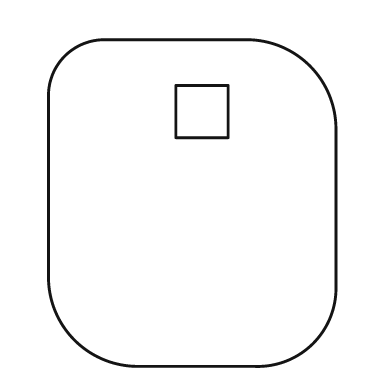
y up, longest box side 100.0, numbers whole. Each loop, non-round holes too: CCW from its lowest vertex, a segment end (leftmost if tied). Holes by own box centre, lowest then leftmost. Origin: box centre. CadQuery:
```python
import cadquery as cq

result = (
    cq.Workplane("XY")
    .moveTo(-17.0, -50.0)
    .lineTo(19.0, -50.0)
    .threePointArc((37.0, -43.0), (44.0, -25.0))
    .lineTo(44.0, 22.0)
    .threePointArc((36.0, 42.0), (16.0, 50.0))
    .lineTo(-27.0, 50.0)
    .threePointArc((-39.0, 45.0), (-44.0, 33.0))
    .lineTo(-44.0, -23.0)
    .threePointArc((-36.0, -42.0), (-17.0, -50.0))
    .close()
    .moveTo(-5.0, 20.0)
    .lineTo(11.0, 20.0)
    .lineTo(11.0, 36.0)
    .lineTo(-5.0, 36.0)
    .close()
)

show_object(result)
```